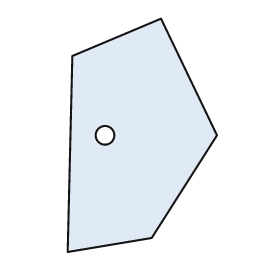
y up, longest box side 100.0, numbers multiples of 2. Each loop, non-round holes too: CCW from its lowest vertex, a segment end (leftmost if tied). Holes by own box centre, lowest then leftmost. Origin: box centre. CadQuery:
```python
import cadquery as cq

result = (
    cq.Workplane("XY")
    .moveTo(-32.0, -50.0)
    .lineTo(4.0, -44.0)
    .lineTo(32.0, 0.0)
    .lineTo(8.0, 50.0)
    .lineTo(-30.0, 34.0)
    .close()
    .moveTo(-16.0, 0.0)
    .circle(4.0)
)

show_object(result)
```